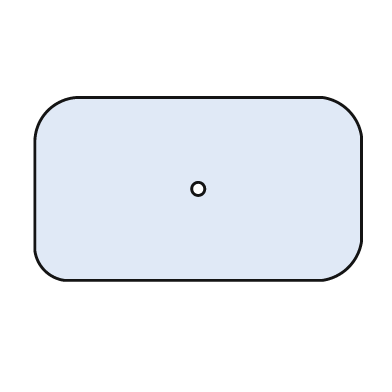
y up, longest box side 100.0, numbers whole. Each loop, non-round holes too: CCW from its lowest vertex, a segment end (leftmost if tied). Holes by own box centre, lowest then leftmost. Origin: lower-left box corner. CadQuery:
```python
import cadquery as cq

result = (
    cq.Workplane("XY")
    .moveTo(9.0, 0.0)
    .lineTo(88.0, 0.0)
    .threePointArc((96.0, 4.0), (100.0, 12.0))
    .lineTo(100.0, 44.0)
    .threePointArc((96.0, 52.0), (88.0, 56.0))
    .lineTo(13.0, 56.0)
    .threePointArc((4.0, 52.0), (0.0, 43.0))
    .lineTo(0.0, 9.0)
    .threePointArc((3.0, 3.0), (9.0, 0.0))
    .close()
    .moveTo(50.0, 28.0)
    .circle(2.0)
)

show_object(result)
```